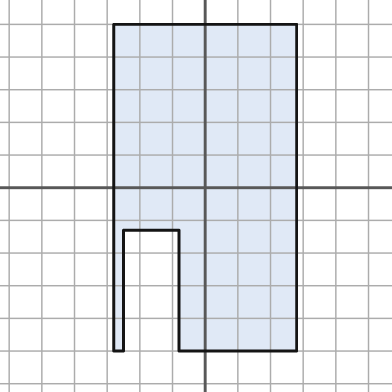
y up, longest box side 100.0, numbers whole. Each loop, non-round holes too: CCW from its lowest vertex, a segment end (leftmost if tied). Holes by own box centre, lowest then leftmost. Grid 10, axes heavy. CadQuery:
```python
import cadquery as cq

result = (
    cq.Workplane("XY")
    .moveTo(-28.0, -50.0)
    .lineTo(-25.0, -50.0)
    .lineTo(-25.0, -13.0)
    .lineTo(-8.0, -13.0)
    .lineTo(-8.0, -50.0)
    .lineTo(28.0, -50.0)
    .lineTo(28.0, 50.0)
    .lineTo(-28.0, 50.0)
    .close()
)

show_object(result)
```